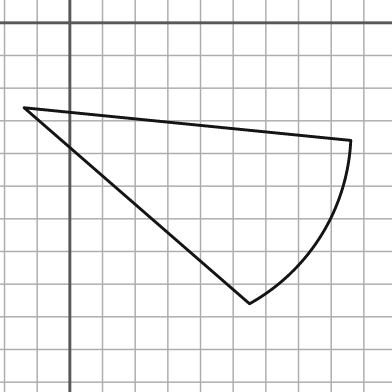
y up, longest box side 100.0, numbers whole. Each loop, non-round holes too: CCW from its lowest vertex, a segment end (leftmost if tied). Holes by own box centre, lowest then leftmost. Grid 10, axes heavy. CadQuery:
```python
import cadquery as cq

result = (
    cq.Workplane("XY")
    .moveTo(55.0, -86.0)
    .threePointArc((77.0, -65.0), (86.0, -36.0))
    .lineTo(-14.0, -26.0)
    .close()
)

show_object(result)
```